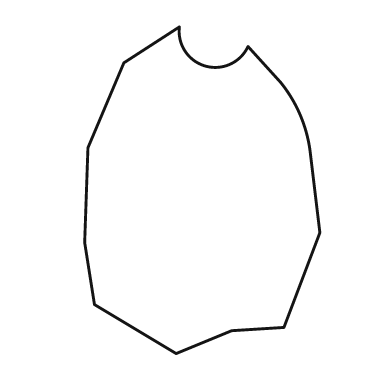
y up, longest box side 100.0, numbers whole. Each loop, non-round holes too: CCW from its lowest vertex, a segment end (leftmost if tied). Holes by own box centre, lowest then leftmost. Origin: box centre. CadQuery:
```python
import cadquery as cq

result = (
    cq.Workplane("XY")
    .moveTo(-8.0, -50.0)
    .lineTo(9.0, -43.0)
    .lineTo(25.0, -42.0)
    .lineTo(36.0, -13.0)
    .lineTo(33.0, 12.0)
    .threePointArc((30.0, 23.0), (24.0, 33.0))
    .lineTo(14.0, 44.0)
    .threePointArc((1.0, 38.0), (-7.0, 50.0))
    .lineTo(-24.0, 39.0)
    .lineTo(-35.0, 13.0)
    .lineTo(-36.0, -16.0)
    .lineTo(-33.0, -35.0)
    .close()
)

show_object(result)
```